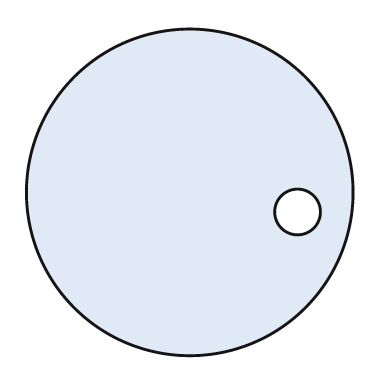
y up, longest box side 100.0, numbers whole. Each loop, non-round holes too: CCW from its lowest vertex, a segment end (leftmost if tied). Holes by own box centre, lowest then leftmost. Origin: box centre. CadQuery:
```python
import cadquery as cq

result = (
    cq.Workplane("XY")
    .moveTo(0.0, 0.0)
    .circle(50.0)
    .moveTo(33.0, -6.0)
    .circle(7.0)
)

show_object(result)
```